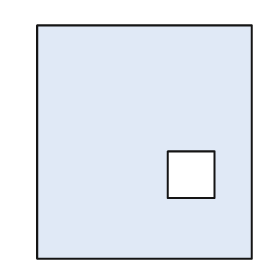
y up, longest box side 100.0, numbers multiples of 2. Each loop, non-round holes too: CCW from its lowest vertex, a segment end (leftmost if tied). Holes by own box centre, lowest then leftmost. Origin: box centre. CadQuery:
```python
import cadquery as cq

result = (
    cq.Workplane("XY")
    .moveTo(-46.0, -50.0)
    .lineTo(46.0, -50.0)
    .lineTo(46.0, 50.0)
    .lineTo(-46.0, 50.0)
    .close()
    .moveTo(10.0, -24.0)
    .lineTo(30.0, -24.0)
    .lineTo(30.0, -4.0)
    .lineTo(10.0, -4.0)
    .close()
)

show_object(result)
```